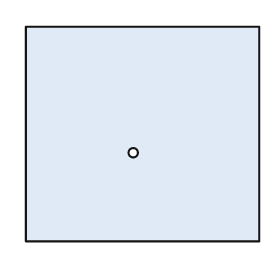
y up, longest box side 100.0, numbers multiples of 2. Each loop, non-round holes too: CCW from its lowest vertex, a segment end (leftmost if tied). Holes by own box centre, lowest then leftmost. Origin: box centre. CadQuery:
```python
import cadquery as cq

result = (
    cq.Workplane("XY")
    .moveTo(-50.0, -46.0)
    .lineTo(50.0, -46.0)
    .lineTo(50.0, 46.0)
    .lineTo(-50.0, 46.0)
    .close()
    .moveTo(-4.0, -8.0)
    .circle(2.0)
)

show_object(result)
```